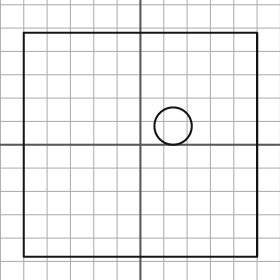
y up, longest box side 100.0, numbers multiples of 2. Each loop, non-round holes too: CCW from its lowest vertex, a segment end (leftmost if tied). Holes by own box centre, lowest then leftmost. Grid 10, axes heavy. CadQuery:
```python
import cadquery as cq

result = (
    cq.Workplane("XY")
    .moveTo(-50.0, -48.0)
    .lineTo(50.0, -48.0)
    .lineTo(50.0, 48.0)
    .lineTo(-50.0, 48.0)
    .close()
    .moveTo(14.0, 8.0)
    .circle(8.0)
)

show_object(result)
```